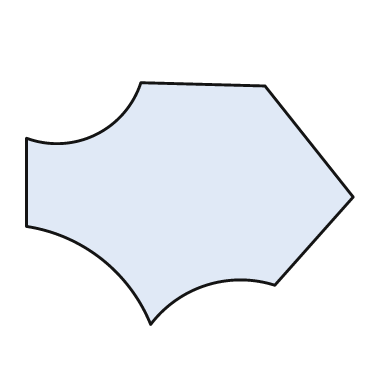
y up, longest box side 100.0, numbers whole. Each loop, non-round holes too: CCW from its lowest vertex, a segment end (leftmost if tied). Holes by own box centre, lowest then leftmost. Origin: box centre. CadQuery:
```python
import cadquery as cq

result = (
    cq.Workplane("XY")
    .moveTo(-12.0, -37.0)
    .threePointArc((5.0, -25.0), (26.0, -25.0))
    .lineTo(50.0, 2.0)
    .lineTo(23.0, 36.0)
    .lineTo(-15.0, 37.0)
    .threePointArc((-29.0, 21.0), (-50.0, 20.0))
    .lineTo(-50.0, -7.0)
    .threePointArc((-27.0, -17.0), (-12.0, -37.0))
    .close()
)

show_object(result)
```